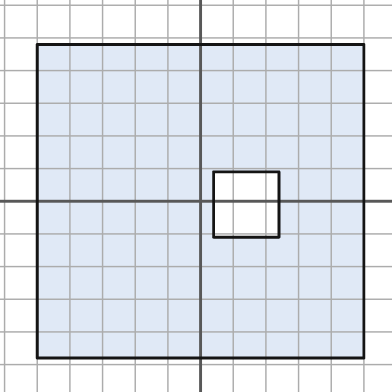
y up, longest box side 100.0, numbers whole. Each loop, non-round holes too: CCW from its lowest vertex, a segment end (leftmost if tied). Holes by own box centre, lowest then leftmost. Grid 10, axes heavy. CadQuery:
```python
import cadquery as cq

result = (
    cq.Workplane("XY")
    .moveTo(-50.0, -48.0)
    .lineTo(50.0, -48.0)
    .lineTo(50.0, 48.0)
    .lineTo(-50.0, 48.0)
    .close()
    .moveTo(4.0, -11.0)
    .lineTo(24.0, -11.0)
    .lineTo(24.0, 9.0)
    .lineTo(4.0, 9.0)
    .close()
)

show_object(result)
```